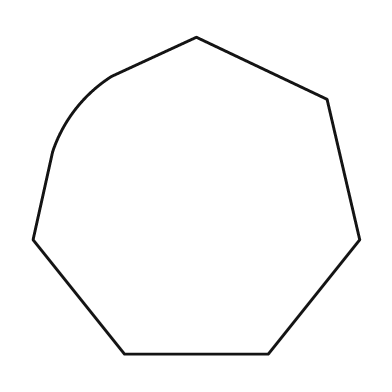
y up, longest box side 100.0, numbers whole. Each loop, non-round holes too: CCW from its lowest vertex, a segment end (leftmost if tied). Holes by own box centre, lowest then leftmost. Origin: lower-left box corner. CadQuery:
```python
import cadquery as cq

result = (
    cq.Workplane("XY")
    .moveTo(28.0, 0.0)
    .lineTo(72.0, 0.0)
    .lineTo(100.0, 35.0)
    .lineTo(90.0, 78.0)
    .lineTo(50.0, 97.0)
    .lineTo(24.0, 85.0)
    .threePointArc((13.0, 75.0), (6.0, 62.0))
    .lineTo(0.0, 35.0)
    .close()
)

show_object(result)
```